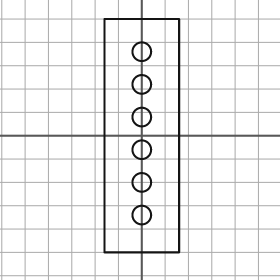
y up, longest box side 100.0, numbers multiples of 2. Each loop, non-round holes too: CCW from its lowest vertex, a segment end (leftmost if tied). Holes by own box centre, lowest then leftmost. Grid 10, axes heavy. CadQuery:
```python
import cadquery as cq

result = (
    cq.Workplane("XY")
    .moveTo(-16.0, -50.0)
    .lineTo(16.0, -50.0)
    .lineTo(16.0, 50.0)
    .lineTo(-16.0, 50.0)
    .close()
    .moveTo(0.0, -34.0)
    .circle(4.0)
    .moveTo(0.0, -20.0)
    .circle(4.0)
    .moveTo(0.0, -6.0)
    .circle(4.0)
    .moveTo(0.0, 8.0)
    .circle(4.0)
    .moveTo(0.0, 22.0)
    .circle(4.0)
    .moveTo(0.0, 36.0)
    .circle(4.0)
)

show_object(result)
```